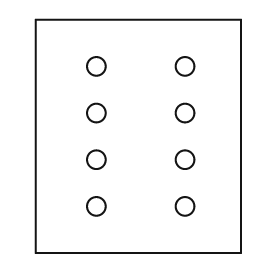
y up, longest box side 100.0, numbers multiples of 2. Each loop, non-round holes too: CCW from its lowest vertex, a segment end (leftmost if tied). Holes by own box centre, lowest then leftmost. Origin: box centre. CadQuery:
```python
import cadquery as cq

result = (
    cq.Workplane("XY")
    .moveTo(-44.0, -50.0)
    .lineTo(44.0, -50.0)
    .lineTo(44.0, 50.0)
    .lineTo(-44.0, 50.0)
    .close()
    .moveTo(-18.0, -30.0)
    .circle(4.0)
    .moveTo(20.0, -30.0)
    .circle(4.0)
    .moveTo(-18.0, -10.0)
    .circle(4.0)
    .moveTo(20.0, -10.0)
    .circle(4.0)
    .moveTo(-18.0, 10.0)
    .circle(4.0)
    .moveTo(20.0, 10.0)
    .circle(4.0)
    .moveTo(-18.0, 30.0)
    .circle(4.0)
    .moveTo(20.0, 30.0)
    .circle(4.0)
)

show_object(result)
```